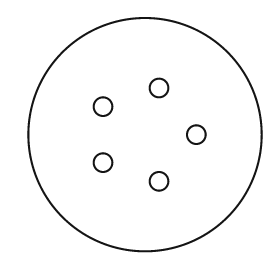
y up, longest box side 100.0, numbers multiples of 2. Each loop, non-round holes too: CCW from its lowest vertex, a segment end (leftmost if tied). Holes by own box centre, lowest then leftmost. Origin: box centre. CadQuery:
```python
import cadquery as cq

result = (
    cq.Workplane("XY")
    .moveTo(0.0, 0.0)
    .circle(50.0)
    .moveTo(6.0, -20.0)
    .circle(4.0)
    .moveTo(-18.0, -12.0)
    .circle(4.0)
    .moveTo(22.0, 0.0)
    .circle(4.0)
    .moveTo(-18.0, 12.0)
    .circle(4.0)
    .moveTo(6.0, 20.0)
    .circle(4.0)
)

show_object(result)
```